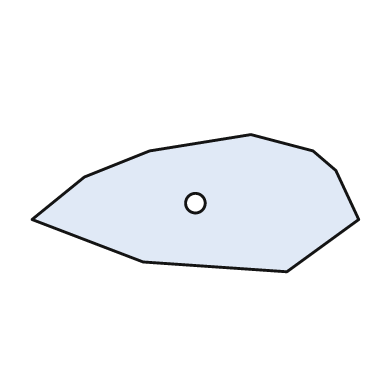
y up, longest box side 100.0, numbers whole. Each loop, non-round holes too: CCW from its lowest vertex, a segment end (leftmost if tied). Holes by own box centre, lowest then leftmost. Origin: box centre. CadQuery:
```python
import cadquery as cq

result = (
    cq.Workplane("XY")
    .moveTo(28.0, -21.0)
    .lineTo(50.0, -5.0)
    .lineTo(43.0, 10.0)
    .lineTo(36.0, 16.0)
    .lineTo(17.0, 21.0)
    .lineTo(-14.0, 16.0)
    .lineTo(-34.0, 8.0)
    .lineTo(-50.0, -5.0)
    .lineTo(-16.0, -18.0)
    .close()
    .moveTo(0.0, 0.0)
    .circle(3.0)
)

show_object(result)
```